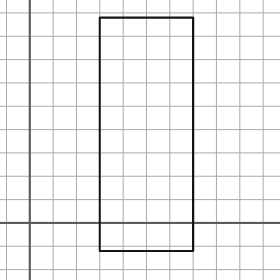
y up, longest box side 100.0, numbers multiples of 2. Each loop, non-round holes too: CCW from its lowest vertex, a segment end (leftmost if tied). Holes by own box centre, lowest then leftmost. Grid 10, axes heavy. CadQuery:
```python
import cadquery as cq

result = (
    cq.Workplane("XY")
    .moveTo(30.0, -12.0)
    .lineTo(70.0, -12.0)
    .lineTo(70.0, 88.0)
    .lineTo(30.0, 88.0)
    .close()
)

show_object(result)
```